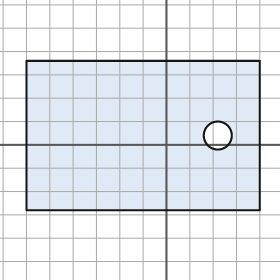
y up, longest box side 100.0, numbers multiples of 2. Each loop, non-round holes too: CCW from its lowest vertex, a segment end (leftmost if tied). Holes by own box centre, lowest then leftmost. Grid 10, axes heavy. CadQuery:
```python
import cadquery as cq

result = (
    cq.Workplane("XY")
    .moveTo(-60.0, -28.0)
    .lineTo(40.0, -28.0)
    .lineTo(40.0, 36.0)
    .lineTo(-60.0, 36.0)
    .close()
    .moveTo(22.0, 4.0)
    .circle(6.0)
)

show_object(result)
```